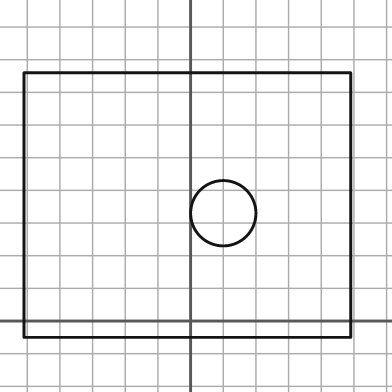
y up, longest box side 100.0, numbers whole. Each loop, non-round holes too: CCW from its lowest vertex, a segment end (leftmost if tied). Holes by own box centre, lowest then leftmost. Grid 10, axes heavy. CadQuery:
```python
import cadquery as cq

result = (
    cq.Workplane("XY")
    .moveTo(-51.0, -5.0)
    .lineTo(49.0, -5.0)
    .lineTo(49.0, 76.0)
    .lineTo(-51.0, 76.0)
    .close()
    .moveTo(10.0, 33.0)
    .circle(10.0)
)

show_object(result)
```